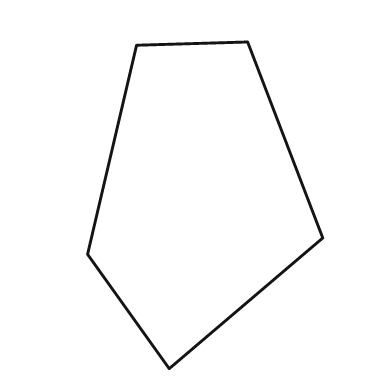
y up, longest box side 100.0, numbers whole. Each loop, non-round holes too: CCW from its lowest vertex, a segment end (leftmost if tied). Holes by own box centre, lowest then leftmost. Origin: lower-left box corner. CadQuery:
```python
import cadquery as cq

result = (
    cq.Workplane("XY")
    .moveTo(25.0, 0.0)
    .lineTo(72.0, 40.0)
    .lineTo(49.0, 100.0)
    .lineTo(15.0, 99.0)
    .lineTo(0.0, 35.0)
    .close()
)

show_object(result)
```